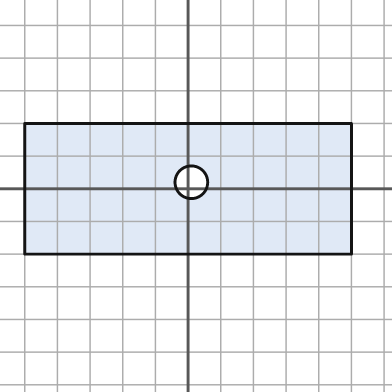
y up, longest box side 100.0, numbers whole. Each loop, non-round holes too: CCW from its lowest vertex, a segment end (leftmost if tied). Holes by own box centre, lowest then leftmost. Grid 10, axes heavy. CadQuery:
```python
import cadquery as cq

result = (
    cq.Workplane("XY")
    .moveTo(-50.0, -20.0)
    .lineTo(50.0, -20.0)
    .lineTo(50.0, 20.0)
    .lineTo(-50.0, 20.0)
    .close()
    .moveTo(1.0, 2.0)
    .circle(5.0)
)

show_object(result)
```